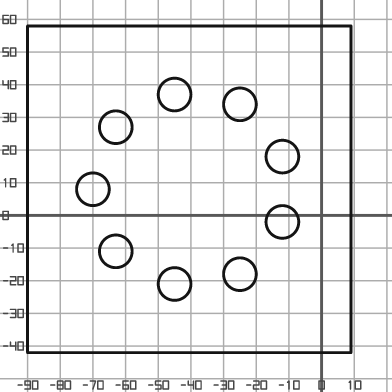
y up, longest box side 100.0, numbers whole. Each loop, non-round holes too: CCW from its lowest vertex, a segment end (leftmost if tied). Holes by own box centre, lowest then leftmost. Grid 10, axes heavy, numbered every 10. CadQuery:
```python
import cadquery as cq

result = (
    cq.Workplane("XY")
    .moveTo(-90.0, -42.0)
    .lineTo(9.0, -42.0)
    .lineTo(9.0, 58.0)
    .lineTo(-90.0, 58.0)
    .close()
    .moveTo(-45.0, -21.0)
    .circle(5.0)
    .moveTo(-25.0, -18.0)
    .circle(5.0)
    .moveTo(-63.0, -11.0)
    .circle(5.0)
    .moveTo(-12.0, -2.0)
    .circle(5.0)
    .moveTo(-70.0, 8.0)
    .circle(5.0)
    .moveTo(-12.0, 18.0)
    .circle(5.0)
    .moveTo(-63.0, 27.0)
    .circle(5.0)
    .moveTo(-25.0, 34.0)
    .circle(5.0)
    .moveTo(-45.0, 37.0)
    .circle(5.0)
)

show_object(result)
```